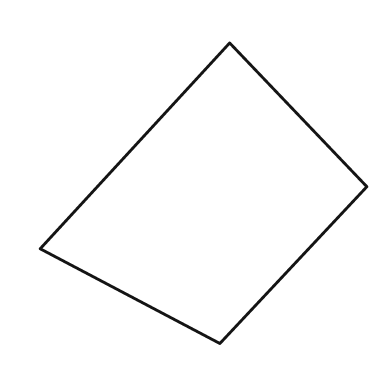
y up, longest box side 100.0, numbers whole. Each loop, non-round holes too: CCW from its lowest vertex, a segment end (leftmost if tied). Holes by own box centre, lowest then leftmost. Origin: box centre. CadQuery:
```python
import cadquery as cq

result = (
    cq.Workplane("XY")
    .moveTo(5.0, -46.0)
    .lineTo(50.0, 2.0)
    .lineTo(8.0, 46.0)
    .lineTo(-50.0, -17.0)
    .close()
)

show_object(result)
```